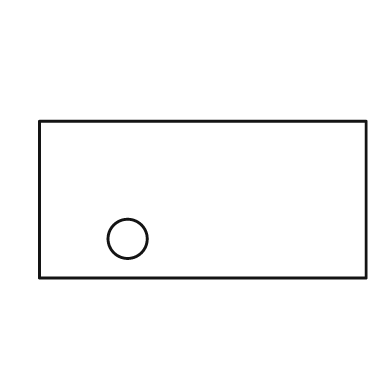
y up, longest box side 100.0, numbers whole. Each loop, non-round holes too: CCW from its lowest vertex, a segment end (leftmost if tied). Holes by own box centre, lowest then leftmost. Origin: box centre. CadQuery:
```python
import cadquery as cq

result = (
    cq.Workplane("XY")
    .moveTo(-50.0, -24.0)
    .lineTo(50.0, -24.0)
    .lineTo(50.0, 24.0)
    .lineTo(-50.0, 24.0)
    .close()
    .moveTo(-23.0, -12.0)
    .circle(6.0)
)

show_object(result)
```